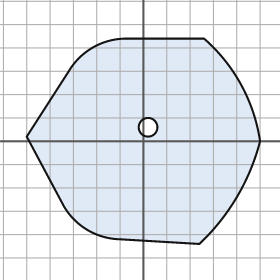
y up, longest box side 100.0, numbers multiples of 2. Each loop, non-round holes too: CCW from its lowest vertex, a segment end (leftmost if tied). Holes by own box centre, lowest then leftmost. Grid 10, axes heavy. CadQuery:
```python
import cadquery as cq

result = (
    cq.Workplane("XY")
    .moveTo(24.0, -44.0)
    .threePointArc((40.0, -24.0), (50.0, 0.0))
    .threePointArc((42.0, 24.0), (26.0, 44.0))
    .lineTo(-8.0, 44.0)
    .threePointArc((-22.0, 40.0), (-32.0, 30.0))
    .lineTo(-50.0, 2.0)
    .lineTo(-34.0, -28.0)
    .threePointArc((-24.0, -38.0), (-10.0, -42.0))
    .close()
    .moveTo(2.0, 6.0)
    .circle(4.0)
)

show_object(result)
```